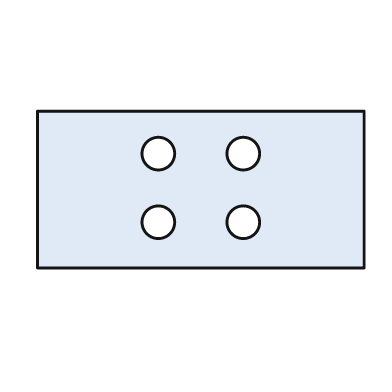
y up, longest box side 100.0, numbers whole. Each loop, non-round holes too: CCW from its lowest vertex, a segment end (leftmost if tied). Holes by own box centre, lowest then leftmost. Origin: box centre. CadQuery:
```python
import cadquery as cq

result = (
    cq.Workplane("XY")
    .moveTo(-50.0, -24.0)
    .lineTo(50.0, -24.0)
    .lineTo(50.0, 24.0)
    .lineTo(-50.0, 24.0)
    .close()
    .moveTo(-13.0, -10.0)
    .circle(5.0)
    .moveTo(13.0, -10.0)
    .circle(5.0)
    .moveTo(-13.0, 11.0)
    .circle(5.0)
    .moveTo(13.0, 11.0)
    .circle(5.0)
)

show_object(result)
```